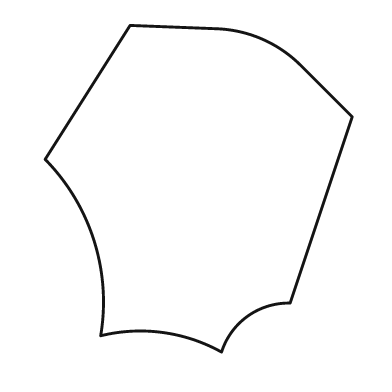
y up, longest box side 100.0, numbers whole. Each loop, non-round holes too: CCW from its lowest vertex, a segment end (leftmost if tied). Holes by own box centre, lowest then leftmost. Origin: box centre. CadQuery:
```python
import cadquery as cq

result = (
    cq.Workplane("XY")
    .moveTo(7.0, -50.0)
    .threePointArc((15.0, -39.0), (28.0, -35.0))
    .lineTo(47.0, 22.0)
    .lineTo(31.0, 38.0)
    .threePointArc((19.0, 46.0), (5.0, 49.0))
    .lineTo(-21.0, 50.0)
    .lineTo(-47.0, 9.0)
    .threePointArc((-32.0, -16.0), (-30.0, -45.0))
    .threePointArc((-11.0, -44.0), (7.0, -50.0))
    .close()
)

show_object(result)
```